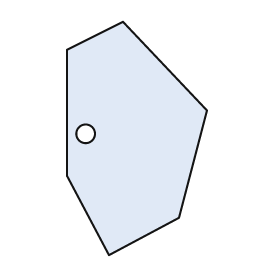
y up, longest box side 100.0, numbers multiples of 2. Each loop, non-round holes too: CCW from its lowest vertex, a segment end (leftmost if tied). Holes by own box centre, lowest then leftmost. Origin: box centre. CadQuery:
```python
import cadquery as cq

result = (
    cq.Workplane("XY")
    .moveTo(-12.0, -50.0)
    .lineTo(18.0, -34.0)
    .lineTo(30.0, 12.0)
    .lineTo(-6.0, 50.0)
    .lineTo(-30.0, 38.0)
    .lineTo(-30.0, -16.0)
    .close()
    .moveTo(-22.0, 2.0)
    .circle(4.0)
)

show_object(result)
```